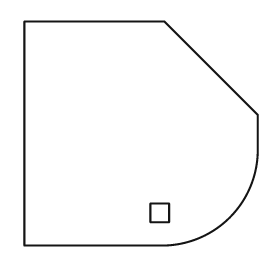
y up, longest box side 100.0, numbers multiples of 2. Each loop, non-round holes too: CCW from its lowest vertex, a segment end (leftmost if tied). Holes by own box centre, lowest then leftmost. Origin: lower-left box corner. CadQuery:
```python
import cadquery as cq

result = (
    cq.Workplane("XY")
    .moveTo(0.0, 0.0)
    .lineTo(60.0, 0.0)
    .threePointArc((88.0, 12.0), (100.0, 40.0))
    .lineTo(100.0, 56.0)
    .lineTo(60.0, 96.0)
    .lineTo(0.0, 96.0)
    .close()
    .moveTo(54.0, 10.0)
    .lineTo(62.0, 10.0)
    .lineTo(62.0, 18.0)
    .lineTo(54.0, 18.0)
    .close()
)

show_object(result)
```